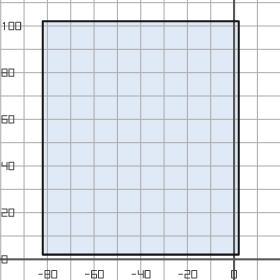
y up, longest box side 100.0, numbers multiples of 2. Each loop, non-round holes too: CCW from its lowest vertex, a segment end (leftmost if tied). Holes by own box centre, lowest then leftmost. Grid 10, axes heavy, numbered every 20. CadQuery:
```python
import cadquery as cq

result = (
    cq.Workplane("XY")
    .moveTo(-82.0, 2.0)
    .lineTo(2.0, 2.0)
    .lineTo(2.0, 102.0)
    .lineTo(-82.0, 102.0)
    .close()
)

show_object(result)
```